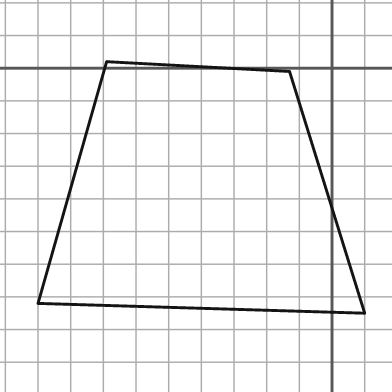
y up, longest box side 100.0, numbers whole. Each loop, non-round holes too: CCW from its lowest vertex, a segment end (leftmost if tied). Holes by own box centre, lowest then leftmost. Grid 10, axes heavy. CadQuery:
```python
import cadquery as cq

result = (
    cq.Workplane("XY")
    .moveTo(10.0, -75.0)
    .lineTo(-13.0, -1.0)
    .lineTo(-69.0, 2.0)
    .lineTo(-90.0, -72.0)
    .close()
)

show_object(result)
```